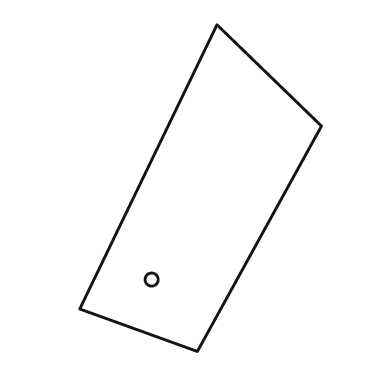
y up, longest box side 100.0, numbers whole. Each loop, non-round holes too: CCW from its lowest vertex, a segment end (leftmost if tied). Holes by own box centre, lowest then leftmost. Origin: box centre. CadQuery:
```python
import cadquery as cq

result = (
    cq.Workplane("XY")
    .moveTo(-1.0, -50.0)
    .lineTo(37.0, 19.0)
    .lineTo(5.0, 50.0)
    .lineTo(-37.0, -37.0)
    .close()
    .moveTo(-15.0, -28.0)
    .circle(2.0)
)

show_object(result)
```